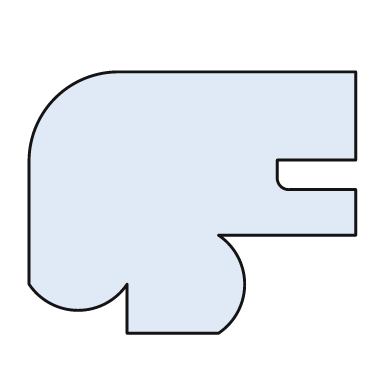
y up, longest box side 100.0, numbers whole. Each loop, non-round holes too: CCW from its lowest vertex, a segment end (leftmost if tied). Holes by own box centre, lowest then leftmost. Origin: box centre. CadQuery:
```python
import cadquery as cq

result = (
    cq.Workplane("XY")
    .moveTo(-20.0, -40.0)
    .lineTo(8.0, -40.0)
    .threePointArc((16.0, -25.0), (8.0, -10.0))
    .lineTo(50.0, -10.0)
    .lineTo(50.0, 4.0)
    .lineTo(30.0, 4.0)
    .threePointArc((27.0, 5.0), (26.0, 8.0))
    .lineTo(26.0, 13.0)
    .lineTo(50.0, 13.0)
    .lineTo(50.0, 40.0)
    .lineTo(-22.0, 40.0)
    .threePointArc((-42.0, 32.0), (-50.0, 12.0))
    .lineTo(-50.0, -25.0)
    .threePointArc((-35.0, -33.0), (-20.0, -25.0))
    .close()
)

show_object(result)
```